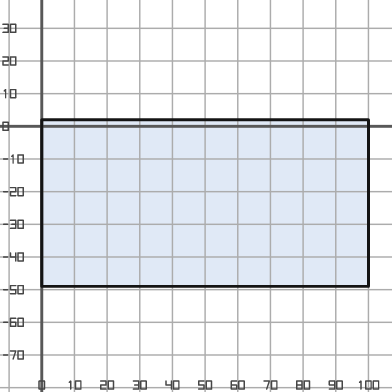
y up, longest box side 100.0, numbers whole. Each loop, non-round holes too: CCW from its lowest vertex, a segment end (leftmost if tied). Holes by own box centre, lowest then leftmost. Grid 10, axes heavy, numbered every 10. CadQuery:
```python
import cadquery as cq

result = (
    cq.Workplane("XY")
    .moveTo(0.0, -49.0)
    .lineTo(100.0, -49.0)
    .lineTo(100.0, 2.0)
    .lineTo(0.0, 2.0)
    .close()
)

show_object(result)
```